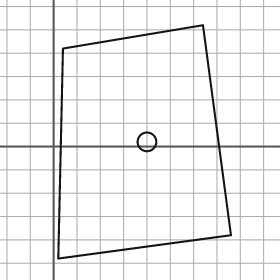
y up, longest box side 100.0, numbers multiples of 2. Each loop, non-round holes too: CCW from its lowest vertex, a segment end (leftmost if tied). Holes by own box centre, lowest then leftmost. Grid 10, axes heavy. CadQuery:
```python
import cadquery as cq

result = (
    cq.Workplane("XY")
    .moveTo(2.0, -48.0)
    .lineTo(76.0, -38.0)
    .lineTo(64.0, 52.0)
    .lineTo(4.0, 42.0)
    .close()
    .moveTo(40.0, 2.0)
    .circle(4.0)
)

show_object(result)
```